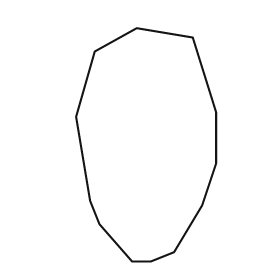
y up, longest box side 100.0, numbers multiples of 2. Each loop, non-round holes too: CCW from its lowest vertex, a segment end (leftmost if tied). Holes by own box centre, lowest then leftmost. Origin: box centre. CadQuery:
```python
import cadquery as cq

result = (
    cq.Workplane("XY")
    .moveTo(-6.0, -50.0)
    .lineTo(2.0, -50.0)
    .lineTo(12.0, -46.0)
    .lineTo(24.0, -26.0)
    .lineTo(30.0, -8.0)
    .lineTo(30.0, 14.0)
    .lineTo(20.0, 46.0)
    .lineTo(-4.0, 50.0)
    .lineTo(-22.0, 40.0)
    .lineTo(-30.0, 12.0)
    .lineTo(-24.0, -24.0)
    .lineTo(-20.0, -34.0)
    .close()
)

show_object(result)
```